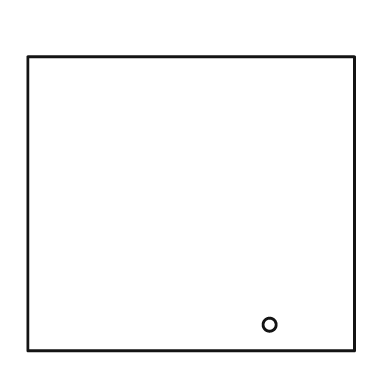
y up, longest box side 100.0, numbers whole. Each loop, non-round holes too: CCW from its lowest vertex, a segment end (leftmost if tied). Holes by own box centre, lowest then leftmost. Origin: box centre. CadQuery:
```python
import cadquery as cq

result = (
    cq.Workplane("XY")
    .moveTo(-50.0, -45.0)
    .lineTo(50.0, -45.0)
    .lineTo(50.0, 45.0)
    .lineTo(-50.0, 45.0)
    .close()
    .moveTo(24.0, -37.0)
    .circle(2.0)
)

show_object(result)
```